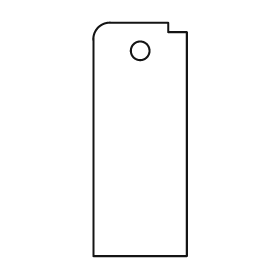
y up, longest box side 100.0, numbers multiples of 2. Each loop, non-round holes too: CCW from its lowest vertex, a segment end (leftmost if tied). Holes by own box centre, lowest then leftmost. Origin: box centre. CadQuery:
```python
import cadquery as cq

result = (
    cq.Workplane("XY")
    .moveTo(-20.0, -50.0)
    .lineTo(20.0, -50.0)
    .lineTo(20.0, 46.0)
    .lineTo(12.0, 46.0)
    .lineTo(12.0, 50.0)
    .lineTo(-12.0, 50.0)
    .threePointArc((-18.0, 48.0), (-20.0, 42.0))
    .close()
    .moveTo(0.0, 38.0)
    .circle(4.0)
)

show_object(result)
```